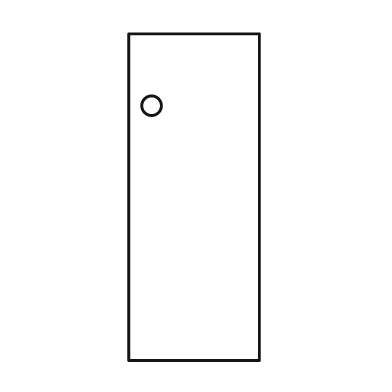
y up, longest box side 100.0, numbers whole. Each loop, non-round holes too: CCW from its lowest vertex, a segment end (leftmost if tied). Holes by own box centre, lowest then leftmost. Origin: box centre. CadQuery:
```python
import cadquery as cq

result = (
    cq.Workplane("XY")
    .moveTo(-20.0, -50.0)
    .lineTo(20.0, -50.0)
    .lineTo(20.0, 50.0)
    .lineTo(-20.0, 50.0)
    .close()
    .moveTo(-13.0, 28.0)
    .circle(3.0)
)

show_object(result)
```